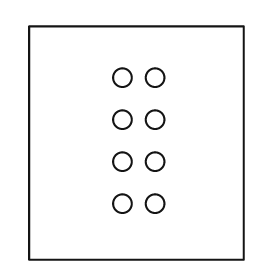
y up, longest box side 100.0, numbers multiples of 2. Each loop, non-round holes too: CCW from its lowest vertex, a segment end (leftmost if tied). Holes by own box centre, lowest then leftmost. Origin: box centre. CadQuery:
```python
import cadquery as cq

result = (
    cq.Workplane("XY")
    .moveTo(-46.0, -50.0)
    .lineTo(46.0, -50.0)
    .lineTo(46.0, 50.0)
    .lineTo(-46.0, 50.0)
    .close()
    .moveTo(-6.0, -26.0)
    .circle(4.0)
    .moveTo(8.0, -26.0)
    .circle(4.0)
    .moveTo(-6.0, -8.0)
    .circle(4.0)
    .moveTo(8.0, -8.0)
    .circle(4.0)
    .moveTo(-6.0, 10.0)
    .circle(4.0)
    .moveTo(8.0, 10.0)
    .circle(4.0)
    .moveTo(-6.0, 28.0)
    .circle(4.0)
    .moveTo(8.0, 28.0)
    .circle(4.0)
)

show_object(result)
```